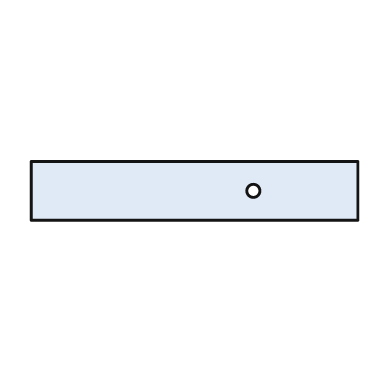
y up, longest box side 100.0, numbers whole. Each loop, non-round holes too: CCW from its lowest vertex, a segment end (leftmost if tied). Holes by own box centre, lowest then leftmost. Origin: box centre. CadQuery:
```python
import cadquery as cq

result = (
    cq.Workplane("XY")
    .moveTo(-50.0, -9.0)
    .lineTo(50.0, -9.0)
    .lineTo(50.0, 9.0)
    .lineTo(-50.0, 9.0)
    .close()
    .moveTo(18.0, 0.0)
    .circle(2.0)
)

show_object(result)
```